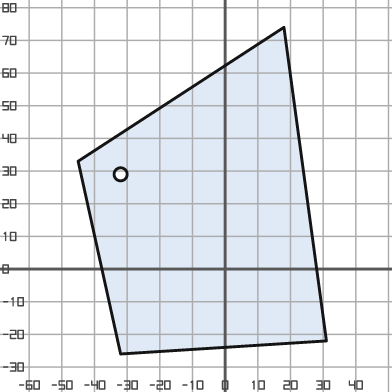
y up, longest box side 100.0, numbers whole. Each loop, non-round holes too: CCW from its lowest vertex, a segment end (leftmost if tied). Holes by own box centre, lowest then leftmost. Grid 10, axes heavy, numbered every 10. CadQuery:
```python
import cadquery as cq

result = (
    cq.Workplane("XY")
    .moveTo(-32.0, -26.0)
    .lineTo(31.0, -22.0)
    .lineTo(18.0, 74.0)
    .lineTo(-45.0, 33.0)
    .close()
    .moveTo(-32.0, 29.0)
    .circle(2.0)
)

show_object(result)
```